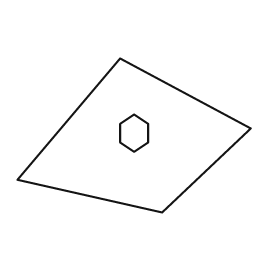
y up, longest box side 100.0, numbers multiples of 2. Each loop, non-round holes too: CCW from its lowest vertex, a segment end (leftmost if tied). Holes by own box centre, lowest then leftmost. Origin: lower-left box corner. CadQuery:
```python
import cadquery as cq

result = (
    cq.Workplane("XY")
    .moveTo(62.0, 0.0)
    .lineTo(100.0, 36.0)
    .lineTo(44.0, 66.0)
    .lineTo(0.0, 14.0)
    .close()
    .moveTo(50.0, 26.0)
    .lineTo(56.0, 30.0)
    .lineTo(56.0, 38.0)
    .lineTo(50.0, 42.0)
    .lineTo(44.0, 38.0)
    .lineTo(44.0, 30.0)
    .close()
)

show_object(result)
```